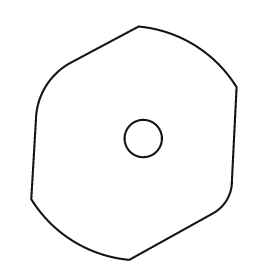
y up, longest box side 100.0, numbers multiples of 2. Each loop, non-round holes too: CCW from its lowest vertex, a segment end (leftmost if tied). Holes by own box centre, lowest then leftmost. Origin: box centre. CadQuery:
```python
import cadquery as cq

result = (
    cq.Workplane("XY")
    .moveTo(-2.0, -50.0)
    .lineTo(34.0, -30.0)
    .threePointArc((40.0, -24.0), (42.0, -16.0))
    .lineTo(44.0, 24.0)
    .threePointArc((26.0, 42.0), (2.0, 50.0))
    .lineTo(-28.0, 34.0)
    .threePointArc((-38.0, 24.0), (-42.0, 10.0))
    .lineTo(-44.0, -24.0)
    .threePointArc((-26.0, -42.0), (-2.0, -50.0))
    .close()
    .moveTo(4.0, 2.0)
    .circle(8.0)
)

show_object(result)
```